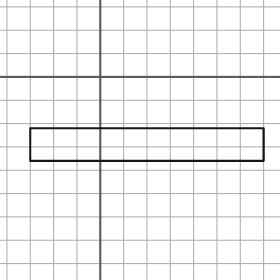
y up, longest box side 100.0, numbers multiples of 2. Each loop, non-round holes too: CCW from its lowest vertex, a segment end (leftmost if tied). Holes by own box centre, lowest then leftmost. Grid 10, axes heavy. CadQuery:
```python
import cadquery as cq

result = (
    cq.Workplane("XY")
    .moveTo(-30.0, -36.0)
    .lineTo(70.0, -36.0)
    .lineTo(70.0, -22.0)
    .lineTo(-30.0, -22.0)
    .close()
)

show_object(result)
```